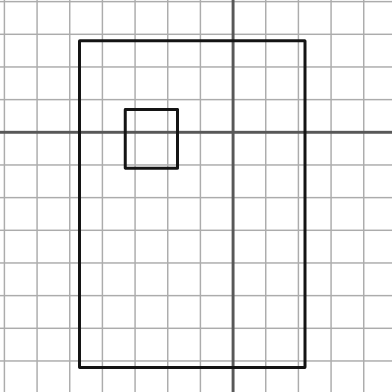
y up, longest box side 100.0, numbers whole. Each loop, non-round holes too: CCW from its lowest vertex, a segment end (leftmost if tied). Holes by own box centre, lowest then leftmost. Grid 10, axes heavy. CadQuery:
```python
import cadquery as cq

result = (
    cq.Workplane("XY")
    .moveTo(-47.0, -72.0)
    .lineTo(22.0, -72.0)
    .lineTo(22.0, 28.0)
    .lineTo(-47.0, 28.0)
    .close()
    .moveTo(-33.0, -11.0)
    .lineTo(-17.0, -11.0)
    .lineTo(-17.0, 7.0)
    .lineTo(-33.0, 7.0)
    .close()
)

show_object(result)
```